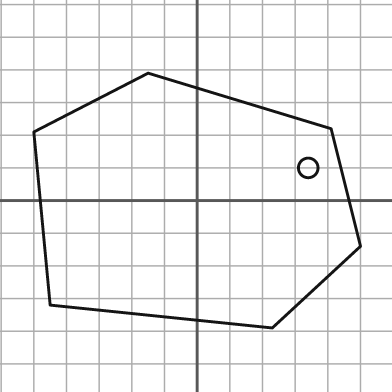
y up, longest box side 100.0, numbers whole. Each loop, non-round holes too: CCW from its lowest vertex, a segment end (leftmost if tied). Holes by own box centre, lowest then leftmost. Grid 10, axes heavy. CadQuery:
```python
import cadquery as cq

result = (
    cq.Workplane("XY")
    .moveTo(23.0, -39.0)
    .lineTo(50.0, -14.0)
    .lineTo(41.0, 22.0)
    .lineTo(-15.0, 39.0)
    .lineTo(-50.0, 21.0)
    .lineTo(-45.0, -32.0)
    .close()
    .moveTo(34.0, 10.0)
    .circle(3.0)
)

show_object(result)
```